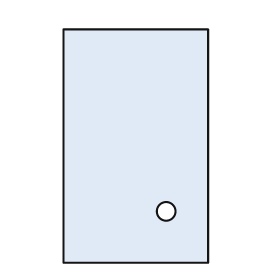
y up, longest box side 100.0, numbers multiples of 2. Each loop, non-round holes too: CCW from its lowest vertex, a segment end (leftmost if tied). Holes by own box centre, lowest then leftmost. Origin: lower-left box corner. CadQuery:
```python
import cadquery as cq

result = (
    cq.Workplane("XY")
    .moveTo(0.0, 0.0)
    .lineTo(62.0, 0.0)
    .lineTo(62.0, 100.0)
    .lineTo(0.0, 100.0)
    .close()
    .moveTo(44.0, 22.0)
    .circle(4.0)
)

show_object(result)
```